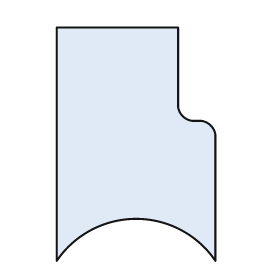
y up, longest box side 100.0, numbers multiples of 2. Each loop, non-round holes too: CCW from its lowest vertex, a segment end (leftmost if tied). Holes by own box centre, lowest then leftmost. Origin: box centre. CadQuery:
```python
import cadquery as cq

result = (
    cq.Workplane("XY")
    .moveTo(-34.0, -50.0)
    .threePointArc((0.0, -32.0), (34.0, -50.0))
    .lineTo(34.0, 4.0)
    .threePointArc((32.0, 8.0), (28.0, 10.0))
    .lineTo(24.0, 10.0)
    .threePointArc((20.0, 12.0), (18.0, 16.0))
    .lineTo(18.0, 50.0)
    .lineTo(-34.0, 50.0)
    .close()
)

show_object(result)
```